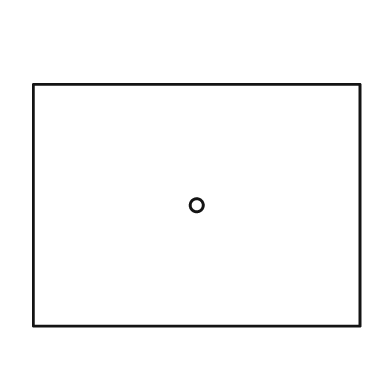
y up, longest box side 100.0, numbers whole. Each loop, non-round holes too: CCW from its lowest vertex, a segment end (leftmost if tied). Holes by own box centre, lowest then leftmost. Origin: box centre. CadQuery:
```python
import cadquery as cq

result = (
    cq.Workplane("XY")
    .moveTo(-50.0, -37.0)
    .lineTo(50.0, -37.0)
    .lineTo(50.0, 37.0)
    .lineTo(-50.0, 37.0)
    .close()
    .moveTo(0.0, 0.0)
    .circle(2.0)
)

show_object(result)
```